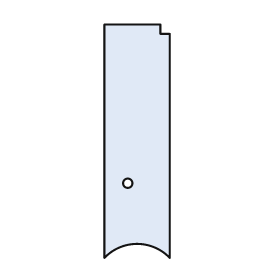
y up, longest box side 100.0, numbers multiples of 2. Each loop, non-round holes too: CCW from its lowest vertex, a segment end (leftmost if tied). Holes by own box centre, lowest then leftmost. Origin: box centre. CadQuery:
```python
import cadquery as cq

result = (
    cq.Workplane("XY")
    .moveTo(-14.0, -50.0)
    .threePointArc((0.0, -44.0), (14.0, -50.0))
    .lineTo(14.0, 46.0)
    .lineTo(10.0, 46.0)
    .lineTo(10.0, 50.0)
    .lineTo(-14.0, 50.0)
    .close()
    .moveTo(-4.0, -18.0)
    .circle(2.0)
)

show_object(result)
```